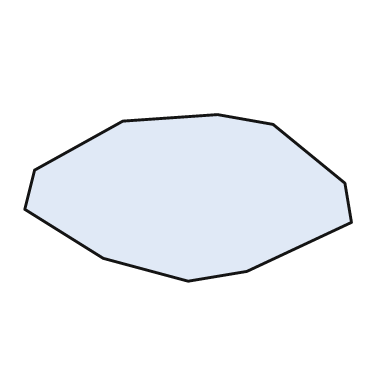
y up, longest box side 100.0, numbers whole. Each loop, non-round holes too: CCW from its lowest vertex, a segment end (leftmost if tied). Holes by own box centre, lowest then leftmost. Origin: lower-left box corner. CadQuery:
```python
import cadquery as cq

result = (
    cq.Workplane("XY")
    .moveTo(50.0, 0.0)
    .lineTo(68.0, 3.0)
    .lineTo(100.0, 18.0)
    .lineTo(98.0, 30.0)
    .lineTo(76.0, 48.0)
    .lineTo(59.0, 51.0)
    .lineTo(30.0, 49.0)
    .lineTo(3.0, 34.0)
    .lineTo(0.0, 22.0)
    .lineTo(24.0, 7.0)
    .close()
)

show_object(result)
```